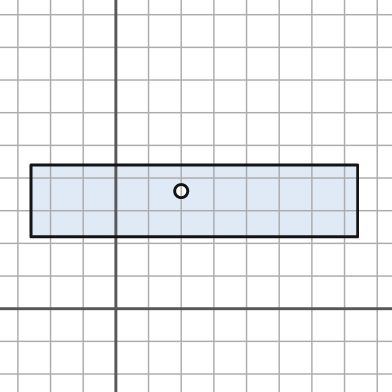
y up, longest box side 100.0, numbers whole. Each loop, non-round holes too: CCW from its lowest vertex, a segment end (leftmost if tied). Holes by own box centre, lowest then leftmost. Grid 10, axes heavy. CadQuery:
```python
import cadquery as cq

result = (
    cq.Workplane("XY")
    .moveTo(-26.0, 22.0)
    .lineTo(74.0, 22.0)
    .lineTo(74.0, 44.0)
    .lineTo(-26.0, 44.0)
    .close()
    .moveTo(20.0, 36.0)
    .circle(2.0)
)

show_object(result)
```